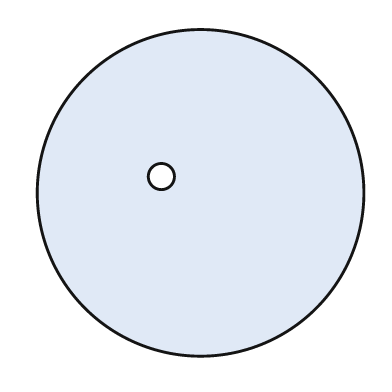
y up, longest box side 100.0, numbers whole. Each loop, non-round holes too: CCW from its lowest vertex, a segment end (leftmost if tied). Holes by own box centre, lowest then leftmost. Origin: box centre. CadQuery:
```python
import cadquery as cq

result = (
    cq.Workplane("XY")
    .moveTo(0.0, 0.0)
    .circle(50.0)
    .moveTo(-12.0, 5.0)
    .circle(4.0)
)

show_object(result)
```